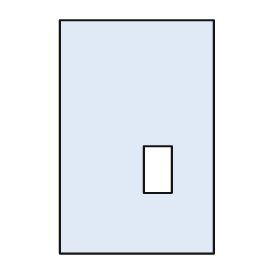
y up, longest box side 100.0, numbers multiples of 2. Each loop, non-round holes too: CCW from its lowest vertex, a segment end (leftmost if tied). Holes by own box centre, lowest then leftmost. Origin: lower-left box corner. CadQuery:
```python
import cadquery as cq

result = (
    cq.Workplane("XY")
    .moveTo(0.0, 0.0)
    .lineTo(66.0, 0.0)
    .lineTo(66.0, 100.0)
    .lineTo(0.0, 100.0)
    .close()
    .moveTo(36.0, 26.0)
    .lineTo(48.0, 26.0)
    .lineTo(48.0, 46.0)
    .lineTo(36.0, 46.0)
    .close()
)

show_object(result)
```